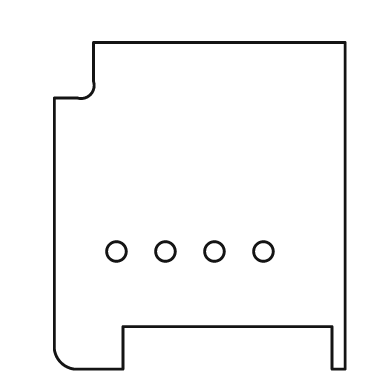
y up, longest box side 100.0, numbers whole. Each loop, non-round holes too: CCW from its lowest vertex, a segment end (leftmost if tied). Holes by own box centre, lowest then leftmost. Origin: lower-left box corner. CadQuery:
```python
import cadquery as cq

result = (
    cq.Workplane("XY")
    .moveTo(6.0, 0.0)
    .lineTo(21.0, 0.0)
    .lineTo(21.0, 13.0)
    .lineTo(85.0, 13.0)
    .lineTo(85.0, 0.0)
    .lineTo(89.0, 0.0)
    .lineTo(89.0, 100.0)
    .lineTo(12.0, 100.0)
    .lineTo(12.0, 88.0)
    .threePointArc((11.0, 84.0), (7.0, 83.0))
    .lineTo(0.0, 83.0)
    .lineTo(0.0, 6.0)
    .threePointArc((2.0, 2.0), (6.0, 0.0))
    .close()
    .moveTo(19.0, 36.0)
    .circle(3.0)
    .moveTo(34.0, 36.0)
    .circle(3.0)
    .moveTo(49.0, 36.0)
    .circle(3.0)
    .moveTo(64.0, 36.0)
    .circle(3.0)
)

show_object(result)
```